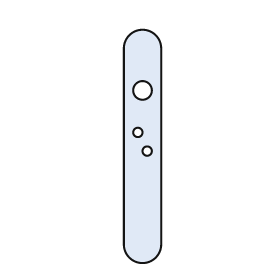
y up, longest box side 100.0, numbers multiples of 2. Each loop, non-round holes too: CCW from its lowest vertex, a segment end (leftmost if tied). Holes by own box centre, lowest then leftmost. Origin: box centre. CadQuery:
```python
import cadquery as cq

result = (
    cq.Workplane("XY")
    .moveTo(-8.0, -42.0)
    .threePointArc((0.0, -50.0), (8.0, -42.0))
    .lineTo(8.0, 42.0)
    .threePointArc((0.0, 50.0), (-8.0, 42.0))
    .close()
    .moveTo(2.0, -2.0)
    .circle(2.0)
    .moveTo(-2.0, 6.0)
    .circle(2.0)
    .moveTo(0.0, 24.0)
    .circle(4.0)
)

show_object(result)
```